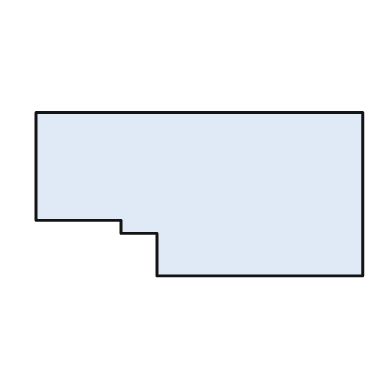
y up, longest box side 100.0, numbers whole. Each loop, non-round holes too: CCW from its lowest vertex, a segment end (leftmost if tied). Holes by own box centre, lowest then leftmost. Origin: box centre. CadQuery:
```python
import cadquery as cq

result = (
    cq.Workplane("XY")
    .moveTo(-13.0, -25.0)
    .lineTo(50.0, -25.0)
    .lineTo(50.0, 25.0)
    .lineTo(-50.0, 25.0)
    .lineTo(-50.0, -8.0)
    .lineTo(-24.0, -8.0)
    .lineTo(-24.0, -12.0)
    .lineTo(-13.0, -12.0)
    .close()
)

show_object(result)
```